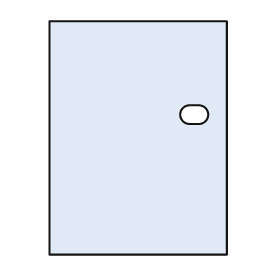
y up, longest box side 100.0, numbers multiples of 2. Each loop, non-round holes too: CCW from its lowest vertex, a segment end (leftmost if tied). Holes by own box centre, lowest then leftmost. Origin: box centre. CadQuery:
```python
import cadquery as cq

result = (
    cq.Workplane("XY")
    .moveTo(-38.0, -50.0)
    .lineTo(38.0, -50.0)
    .lineTo(38.0, 50.0)
    .lineTo(-38.0, 50.0)
    .close()
    .moveTo(22.0, 6.0)
    .lineTo(26.0, 6.0)
    .threePointArc((30.0, 10.0), (26.0, 14.0))
    .lineTo(22.0, 14.0)
    .threePointArc((18.0, 10.0), (22.0, 6.0))
    .close()
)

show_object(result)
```